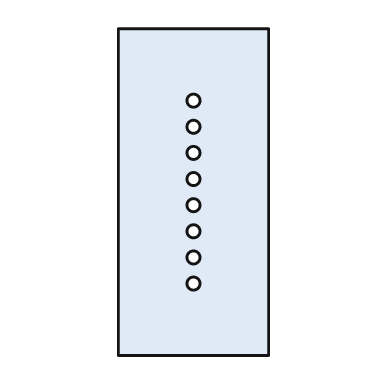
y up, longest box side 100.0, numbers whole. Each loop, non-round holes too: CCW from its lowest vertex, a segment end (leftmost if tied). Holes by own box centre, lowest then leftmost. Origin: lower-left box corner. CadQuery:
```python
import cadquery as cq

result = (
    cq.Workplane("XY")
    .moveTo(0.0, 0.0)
    .lineTo(46.0, 0.0)
    .lineTo(46.0, 100.0)
    .lineTo(0.0, 100.0)
    .close()
    .moveTo(23.0, 22.0)
    .circle(2.0)
    .moveTo(23.0, 30.0)
    .circle(2.0)
    .moveTo(23.0, 38.0)
    .circle(2.0)
    .moveTo(23.0, 46.0)
    .circle(2.0)
    .moveTo(23.0, 54.0)
    .circle(2.0)
    .moveTo(23.0, 62.0)
    .circle(2.0)
    .moveTo(23.0, 70.0)
    .circle(2.0)
    .moveTo(23.0, 78.0)
    .circle(2.0)
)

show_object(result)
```